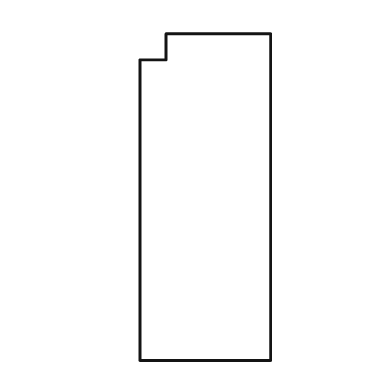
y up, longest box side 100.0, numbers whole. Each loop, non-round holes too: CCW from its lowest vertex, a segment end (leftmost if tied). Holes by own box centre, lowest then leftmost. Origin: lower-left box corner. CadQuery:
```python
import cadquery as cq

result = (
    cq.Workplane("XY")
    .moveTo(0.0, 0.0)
    .lineTo(40.0, 0.0)
    .lineTo(40.0, 100.0)
    .lineTo(8.0, 100.0)
    .lineTo(8.0, 92.0)
    .lineTo(0.0, 92.0)
    .close()
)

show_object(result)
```